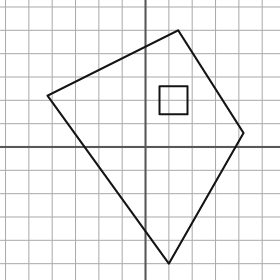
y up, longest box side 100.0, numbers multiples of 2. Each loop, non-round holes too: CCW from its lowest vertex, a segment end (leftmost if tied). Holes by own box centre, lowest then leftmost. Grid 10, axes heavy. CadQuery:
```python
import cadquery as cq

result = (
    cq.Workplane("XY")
    .moveTo(10.0, -50.0)
    .lineTo(42.0, 6.0)
    .lineTo(14.0, 50.0)
    .lineTo(-42.0, 22.0)
    .close()
    .moveTo(6.0, 14.0)
    .lineTo(18.0, 14.0)
    .lineTo(18.0, 26.0)
    .lineTo(6.0, 26.0)
    .close()
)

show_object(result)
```